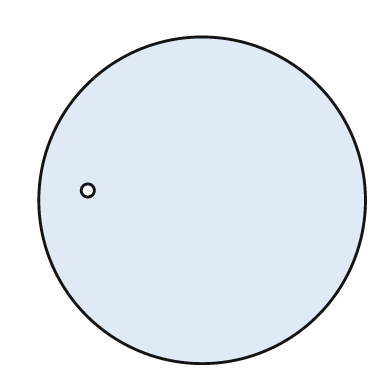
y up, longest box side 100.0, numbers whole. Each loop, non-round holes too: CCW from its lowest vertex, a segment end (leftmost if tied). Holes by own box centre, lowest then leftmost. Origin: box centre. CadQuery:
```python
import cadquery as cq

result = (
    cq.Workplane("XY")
    .moveTo(0.0, 0.0)
    .circle(50.0)
    .moveTo(-35.0, 3.0)
    .circle(2.0)
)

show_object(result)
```